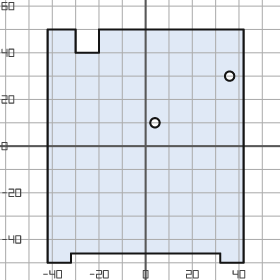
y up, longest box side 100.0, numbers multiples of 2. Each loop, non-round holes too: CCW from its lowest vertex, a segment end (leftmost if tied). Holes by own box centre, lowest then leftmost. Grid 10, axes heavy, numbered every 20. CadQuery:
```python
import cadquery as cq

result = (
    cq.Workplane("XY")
    .moveTo(-42.0, -50.0)
    .lineTo(-32.0, -50.0)
    .lineTo(-32.0, -46.0)
    .lineTo(32.0, -46.0)
    .lineTo(32.0, -50.0)
    .lineTo(42.0, -50.0)
    .lineTo(42.0, 50.0)
    .lineTo(-20.0, 50.0)
    .lineTo(-20.0, 40.0)
    .lineTo(-30.0, 40.0)
    .lineTo(-30.0, 50.0)
    .lineTo(-42.0, 50.0)
    .close()
    .moveTo(4.0, 10.0)
    .circle(2.0)
    .moveTo(36.0, 30.0)
    .circle(2.0)
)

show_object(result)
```